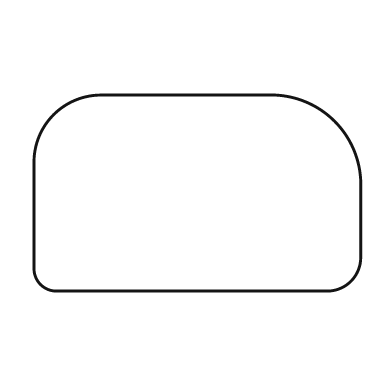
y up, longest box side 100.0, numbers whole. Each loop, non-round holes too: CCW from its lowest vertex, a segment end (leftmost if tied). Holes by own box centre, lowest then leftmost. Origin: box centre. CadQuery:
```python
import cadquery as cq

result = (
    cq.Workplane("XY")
    .moveTo(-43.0, -30.0)
    .lineTo(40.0, -30.0)
    .threePointArc((47.0, -27.0), (50.0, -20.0))
    .lineTo(50.0, 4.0)
    .threePointArc((42.0, 22.0), (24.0, 30.0))
    .lineTo(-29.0, 30.0)
    .threePointArc((-44.0, 24.0), (-50.0, 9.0))
    .lineTo(-50.0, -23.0)
    .threePointArc((-48.0, -28.0), (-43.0, -30.0))
    .close()
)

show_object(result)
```